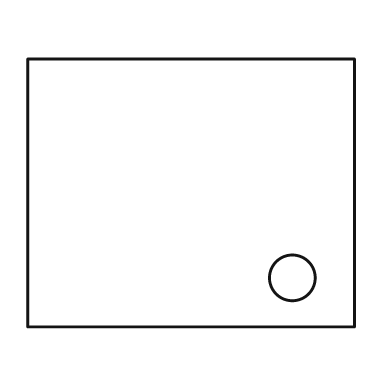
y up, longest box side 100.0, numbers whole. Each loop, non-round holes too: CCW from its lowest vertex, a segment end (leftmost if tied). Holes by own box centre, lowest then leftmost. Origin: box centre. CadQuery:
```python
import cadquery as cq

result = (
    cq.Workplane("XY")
    .moveTo(-50.0, -41.0)
    .lineTo(50.0, -41.0)
    .lineTo(50.0, 41.0)
    .lineTo(-50.0, 41.0)
    .close()
    .moveTo(31.0, -26.0)
    .circle(7.0)
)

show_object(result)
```